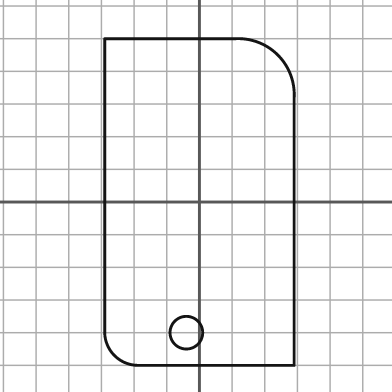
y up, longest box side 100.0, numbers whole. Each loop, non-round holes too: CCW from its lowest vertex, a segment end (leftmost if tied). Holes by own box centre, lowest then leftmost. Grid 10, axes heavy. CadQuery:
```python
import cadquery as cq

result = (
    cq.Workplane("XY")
    .moveTo(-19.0, -50.0)
    .lineTo(29.0, -50.0)
    .lineTo(29.0, 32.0)
    .threePointArc((24.0, 45.0), (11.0, 50.0))
    .lineTo(-29.0, 50.0)
    .lineTo(-29.0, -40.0)
    .threePointArc((-26.0, -47.0), (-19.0, -50.0))
    .close()
    .moveTo(-4.0, -40.0)
    .circle(5.0)
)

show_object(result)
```